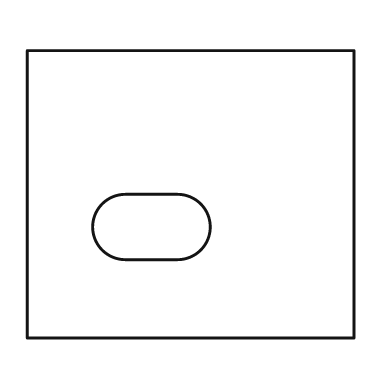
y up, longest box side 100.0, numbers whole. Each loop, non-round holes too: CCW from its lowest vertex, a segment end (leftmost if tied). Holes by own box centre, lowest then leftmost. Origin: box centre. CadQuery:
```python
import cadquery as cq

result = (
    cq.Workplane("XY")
    .moveTo(-50.0, -44.0)
    .lineTo(50.0, -44.0)
    .lineTo(50.0, 44.0)
    .lineTo(-50.0, 44.0)
    .close()
    .moveTo(-20.0, -20.0)
    .lineTo(-4.0, -20.0)
    .threePointArc((6.0, -10.0), (-4.0, 0.0))
    .lineTo(-20.0, 0.0)
    .threePointArc((-30.0, -10.0), (-20.0, -20.0))
    .close()
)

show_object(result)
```